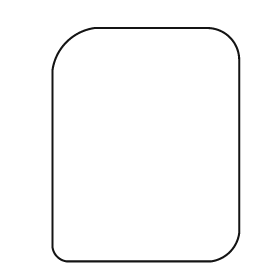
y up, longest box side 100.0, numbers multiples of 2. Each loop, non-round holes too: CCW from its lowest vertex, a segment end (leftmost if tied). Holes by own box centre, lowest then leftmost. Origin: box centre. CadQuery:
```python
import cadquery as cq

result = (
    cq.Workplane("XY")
    .moveTo(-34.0, -50.0)
    .lineTo(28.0, -50.0)
    .threePointArc((36.0, -46.0), (40.0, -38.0))
    .lineTo(40.0, 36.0)
    .threePointArc((36.0, 46.0), (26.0, 50.0))
    .lineTo(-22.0, 50.0)
    .threePointArc((-34.0, 44.0), (-40.0, 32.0))
    .lineTo(-40.0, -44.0)
    .threePointArc((-38.0, -48.0), (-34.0, -50.0))
    .close()
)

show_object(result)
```